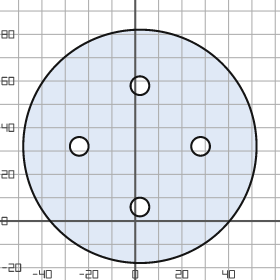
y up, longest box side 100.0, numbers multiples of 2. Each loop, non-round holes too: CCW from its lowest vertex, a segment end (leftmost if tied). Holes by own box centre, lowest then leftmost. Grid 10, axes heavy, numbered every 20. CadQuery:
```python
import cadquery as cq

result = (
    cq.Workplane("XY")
    .moveTo(2.0, 32.0)
    .circle(50.0)
    .moveTo(2.0, 6.0)
    .circle(4.0)
    .moveTo(-24.0, 32.0)
    .circle(4.0)
    .moveTo(28.0, 32.0)
    .circle(4.0)
    .moveTo(2.0, 58.0)
    .circle(4.0)
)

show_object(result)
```